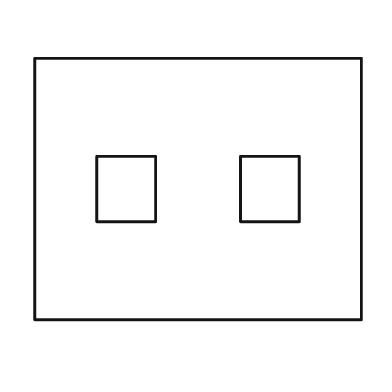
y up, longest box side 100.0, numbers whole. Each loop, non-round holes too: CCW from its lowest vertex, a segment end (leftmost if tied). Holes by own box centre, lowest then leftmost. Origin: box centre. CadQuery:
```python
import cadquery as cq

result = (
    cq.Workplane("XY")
    .moveTo(-50.0, -40.0)
    .lineTo(50.0, -40.0)
    .lineTo(50.0, 40.0)
    .lineTo(-50.0, 40.0)
    .close()
    .moveTo(-31.0, -10.0)
    .lineTo(-13.0, -10.0)
    .lineTo(-13.0, 10.0)
    .lineTo(-31.0, 10.0)
    .close()
    .moveTo(13.0, -10.0)
    .lineTo(31.0, -10.0)
    .lineTo(31.0, 10.0)
    .lineTo(13.0, 10.0)
    .close()
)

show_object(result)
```